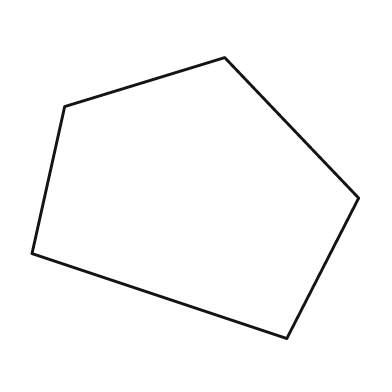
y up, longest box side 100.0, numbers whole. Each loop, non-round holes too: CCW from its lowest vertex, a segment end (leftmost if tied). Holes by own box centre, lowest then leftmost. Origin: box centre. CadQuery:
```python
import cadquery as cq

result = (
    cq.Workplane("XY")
    .moveTo(28.0, -43.0)
    .lineTo(50.0, 0.0)
    .lineTo(9.0, 43.0)
    .lineTo(-40.0, 28.0)
    .lineTo(-50.0, -17.0)
    .close()
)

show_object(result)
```